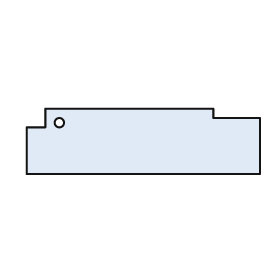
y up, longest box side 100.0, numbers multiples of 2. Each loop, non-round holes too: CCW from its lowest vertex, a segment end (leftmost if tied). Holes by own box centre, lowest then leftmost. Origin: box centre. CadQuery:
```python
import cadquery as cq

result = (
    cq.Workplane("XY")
    .moveTo(-50.0, -14.0)
    .lineTo(50.0, -14.0)
    .lineTo(50.0, 10.0)
    .lineTo(30.0, 10.0)
    .lineTo(30.0, 14.0)
    .lineTo(-42.0, 14.0)
    .lineTo(-42.0, 6.0)
    .lineTo(-50.0, 6.0)
    .close()
    .moveTo(-36.0, 8.0)
    .circle(2.0)
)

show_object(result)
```